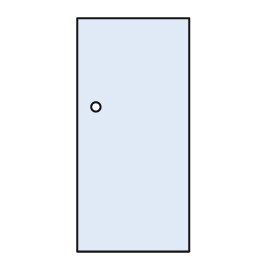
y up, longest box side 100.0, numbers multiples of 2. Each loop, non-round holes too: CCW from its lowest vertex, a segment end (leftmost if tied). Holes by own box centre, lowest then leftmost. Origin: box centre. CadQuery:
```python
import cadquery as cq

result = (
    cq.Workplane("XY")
    .moveTo(-24.0, -50.0)
    .lineTo(24.0, -50.0)
    .lineTo(24.0, 50.0)
    .lineTo(-24.0, 50.0)
    .close()
    .moveTo(-16.0, 12.0)
    .circle(2.0)
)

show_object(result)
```